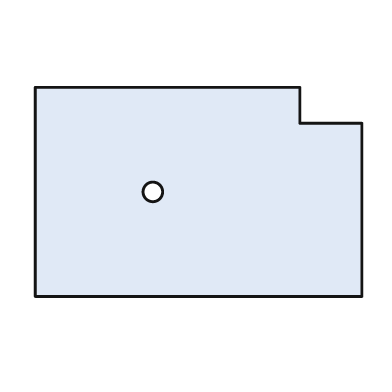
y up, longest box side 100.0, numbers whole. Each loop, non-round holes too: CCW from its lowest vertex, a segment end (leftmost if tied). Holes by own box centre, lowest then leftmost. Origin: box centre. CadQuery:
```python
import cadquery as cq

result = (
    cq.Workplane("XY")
    .moveTo(-50.0, -32.0)
    .lineTo(50.0, -32.0)
    .lineTo(50.0, 21.0)
    .lineTo(31.0, 21.0)
    .lineTo(31.0, 32.0)
    .lineTo(-50.0, 32.0)
    .close()
    .moveTo(-14.0, 0.0)
    .circle(3.0)
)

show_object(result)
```